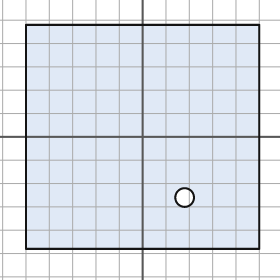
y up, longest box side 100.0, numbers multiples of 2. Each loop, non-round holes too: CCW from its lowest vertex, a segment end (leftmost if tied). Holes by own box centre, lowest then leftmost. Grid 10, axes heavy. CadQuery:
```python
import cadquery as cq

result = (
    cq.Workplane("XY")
    .moveTo(-50.0, -48.0)
    .lineTo(50.0, -48.0)
    .lineTo(50.0, 48.0)
    .lineTo(-50.0, 48.0)
    .close()
    .moveTo(18.0, -26.0)
    .circle(4.0)
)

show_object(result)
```